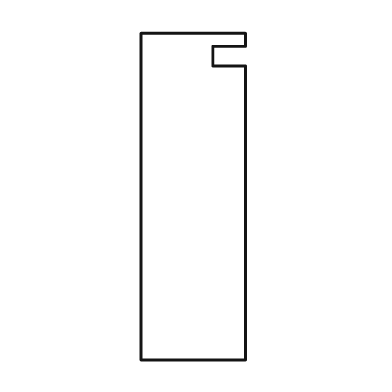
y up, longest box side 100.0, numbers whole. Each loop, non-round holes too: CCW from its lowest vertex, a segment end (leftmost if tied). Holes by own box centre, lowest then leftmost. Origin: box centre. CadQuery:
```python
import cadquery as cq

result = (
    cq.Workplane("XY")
    .moveTo(-16.0, -50.0)
    .lineTo(16.0, -50.0)
    .lineTo(16.0, 40.0)
    .lineTo(6.0, 40.0)
    .lineTo(6.0, 46.0)
    .lineTo(16.0, 46.0)
    .lineTo(16.0, 50.0)
    .lineTo(-16.0, 50.0)
    .close()
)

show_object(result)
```